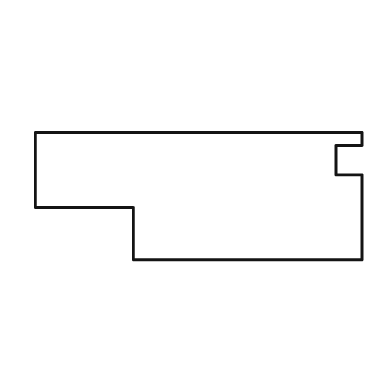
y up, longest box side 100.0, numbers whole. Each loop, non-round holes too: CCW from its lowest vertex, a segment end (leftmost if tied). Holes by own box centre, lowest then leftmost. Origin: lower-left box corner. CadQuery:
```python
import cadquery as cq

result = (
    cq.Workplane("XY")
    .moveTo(30.0, 0.0)
    .lineTo(100.0, 0.0)
    .lineTo(100.0, 26.0)
    .lineTo(92.0, 26.0)
    .lineTo(92.0, 35.0)
    .lineTo(100.0, 35.0)
    .lineTo(100.0, 39.0)
    .lineTo(0.0, 39.0)
    .lineTo(0.0, 16.0)
    .lineTo(30.0, 16.0)
    .close()
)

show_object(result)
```